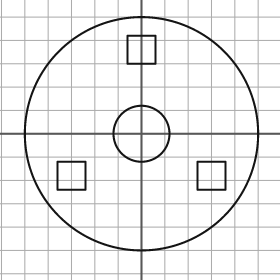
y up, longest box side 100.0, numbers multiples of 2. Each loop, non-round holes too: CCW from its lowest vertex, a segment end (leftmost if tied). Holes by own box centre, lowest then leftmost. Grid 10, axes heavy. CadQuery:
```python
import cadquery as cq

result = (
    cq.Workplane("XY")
    .moveTo(0.0, 0.0)
    .circle(50.0)
    .moveTo(-36.0, -24.0)
    .lineTo(-24.0, -24.0)
    .lineTo(-24.0, -12.0)
    .lineTo(-36.0, -12.0)
    .close()
    .moveTo(24.0, -24.0)
    .lineTo(36.0, -24.0)
    .lineTo(36.0, -12.0)
    .lineTo(24.0, -12.0)
    .close()
    .moveTo(0.0, 0.0)
    .circle(12.0)
    .moveTo(-6.0, 30.0)
    .lineTo(6.0, 30.0)
    .lineTo(6.0, 42.0)
    .lineTo(-6.0, 42.0)
    .close()
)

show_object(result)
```